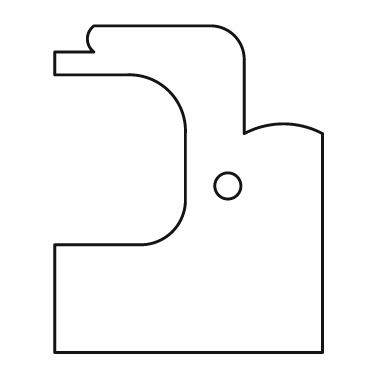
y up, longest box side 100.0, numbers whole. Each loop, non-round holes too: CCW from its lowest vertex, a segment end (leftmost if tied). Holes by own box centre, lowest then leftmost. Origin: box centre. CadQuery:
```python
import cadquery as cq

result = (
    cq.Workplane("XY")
    .moveTo(-41.0, -50.0)
    .lineTo(41.0, -50.0)
    .lineTo(41.0, 17.0)
    .threePointArc((29.0, 20.0), (17.0, 17.0))
    .lineTo(17.0, 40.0)
    .threePointArc((14.0, 47.0), (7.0, 50.0))
    .lineTo(-29.0, 50.0)
    .threePointArc((-31.0, 46.0), (-29.0, 42.0))
    .lineTo(-41.0, 42.0)
    .lineTo(-41.0, 35.0)
    .lineTo(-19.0, 35.0)
    .threePointArc((-6.0, 30.0), (-1.0, 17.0))
    .lineTo(-1.0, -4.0)
    .threePointArc((-5.0, -13.0), (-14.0, -17.0))
    .lineTo(-41.0, -17.0)
    .close()
    .moveTo(12.0, 1.0)
    .circle(4.0)
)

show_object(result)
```